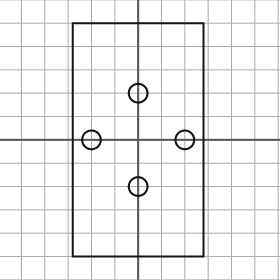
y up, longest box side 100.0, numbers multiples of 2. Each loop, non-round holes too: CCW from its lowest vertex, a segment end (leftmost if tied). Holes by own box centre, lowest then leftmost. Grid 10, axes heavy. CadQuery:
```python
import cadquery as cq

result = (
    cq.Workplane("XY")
    .moveTo(-28.0, -50.0)
    .lineTo(28.0, -50.0)
    .lineTo(28.0, 50.0)
    .lineTo(-28.0, 50.0)
    .close()
    .moveTo(0.0, -20.0)
    .circle(4.0)
    .moveTo(-20.0, 0.0)
    .circle(4.0)
    .moveTo(20.0, 0.0)
    .circle(4.0)
    .moveTo(0.0, 20.0)
    .circle(4.0)
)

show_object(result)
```